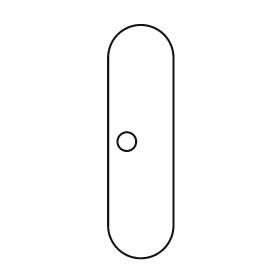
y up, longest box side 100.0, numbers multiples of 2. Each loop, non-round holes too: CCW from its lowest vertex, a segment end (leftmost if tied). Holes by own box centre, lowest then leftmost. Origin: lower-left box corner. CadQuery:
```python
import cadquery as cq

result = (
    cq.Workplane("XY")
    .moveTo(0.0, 14.0)
    .threePointArc((14.0, 0.0), (28.0, 14.0))
    .lineTo(28.0, 86.0)
    .threePointArc((14.0, 100.0), (0.0, 86.0))
    .close()
    .moveTo(8.0, 50.0)
    .circle(4.0)
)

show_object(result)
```